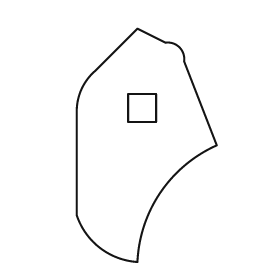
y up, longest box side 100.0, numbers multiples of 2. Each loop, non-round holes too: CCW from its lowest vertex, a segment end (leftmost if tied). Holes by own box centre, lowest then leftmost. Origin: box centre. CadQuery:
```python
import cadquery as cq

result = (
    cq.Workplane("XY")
    .moveTo(-4.0, -50.0)
    .threePointArc((6.0, -20.0), (30.0, 0.0))
    .lineTo(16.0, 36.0)
    .threePointArc((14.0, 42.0), (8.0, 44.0))
    .lineTo(-4.0, 50.0)
    .lineTo(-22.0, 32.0)
    .threePointArc((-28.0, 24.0), (-30.0, 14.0))
    .lineTo(-30.0, -30.0)
    .threePointArc((-20.0, -44.0), (-4.0, -50.0))
    .close()
    .moveTo(-8.0, 10.0)
    .lineTo(4.0, 10.0)
    .lineTo(4.0, 22.0)
    .lineTo(-8.0, 22.0)
    .close()
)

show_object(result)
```